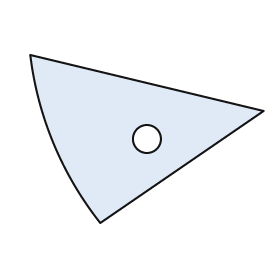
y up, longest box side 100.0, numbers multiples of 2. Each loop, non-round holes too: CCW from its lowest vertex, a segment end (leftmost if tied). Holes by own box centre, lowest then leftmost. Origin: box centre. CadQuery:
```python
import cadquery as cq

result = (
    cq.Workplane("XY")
    .moveTo(-20.0, -36.0)
    .lineTo(50.0, 12.0)
    .lineTo(-50.0, 36.0)
    .threePointArc((-40.0, -2.0), (-20.0, -36.0))
    .close()
    .moveTo(0.0, 0.0)
    .circle(6.0)
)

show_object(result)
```